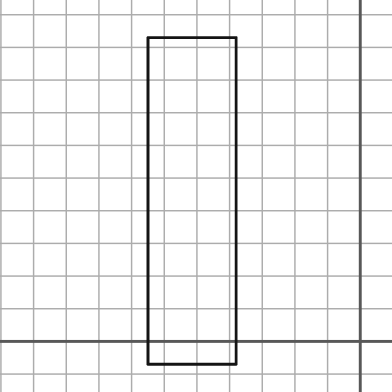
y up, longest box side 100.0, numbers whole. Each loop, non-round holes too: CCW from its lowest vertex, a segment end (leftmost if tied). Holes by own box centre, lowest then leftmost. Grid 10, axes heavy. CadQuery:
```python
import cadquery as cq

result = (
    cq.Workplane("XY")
    .moveTo(-65.0, -7.0)
    .lineTo(-38.0, -7.0)
    .lineTo(-38.0, 93.0)
    .lineTo(-65.0, 93.0)
    .close()
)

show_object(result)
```